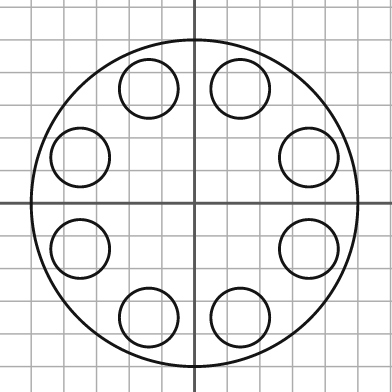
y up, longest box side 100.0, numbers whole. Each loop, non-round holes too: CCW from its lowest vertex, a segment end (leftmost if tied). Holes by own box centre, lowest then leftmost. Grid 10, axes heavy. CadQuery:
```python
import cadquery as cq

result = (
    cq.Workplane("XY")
    .moveTo(0.0, 0.0)
    .circle(50.0)
    .moveTo(-14.0, -35.0)
    .circle(9.0)
    .moveTo(14.0, -35.0)
    .circle(9.0)
    .moveTo(-35.0, -14.0)
    .circle(9.0)
    .moveTo(35.0, -14.0)
    .circle(9.0)
    .moveTo(-35.0, 14.0)
    .circle(9.0)
    .moveTo(35.0, 14.0)
    .circle(9.0)
    .moveTo(-14.0, 35.0)
    .circle(9.0)
    .moveTo(14.0, 35.0)
    .circle(9.0)
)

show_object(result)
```